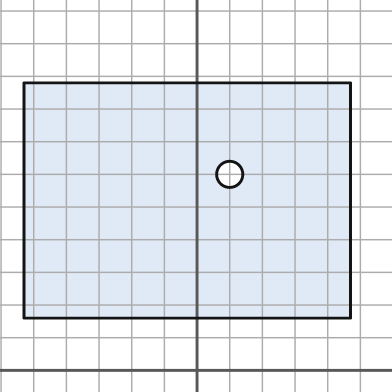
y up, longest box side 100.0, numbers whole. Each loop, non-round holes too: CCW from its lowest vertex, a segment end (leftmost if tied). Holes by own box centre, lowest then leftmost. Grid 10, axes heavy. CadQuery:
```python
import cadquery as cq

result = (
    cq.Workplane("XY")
    .moveTo(-53.0, 16.0)
    .lineTo(47.0, 16.0)
    .lineTo(47.0, 88.0)
    .lineTo(-53.0, 88.0)
    .close()
    .moveTo(10.0, 60.0)
    .circle(4.0)
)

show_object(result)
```